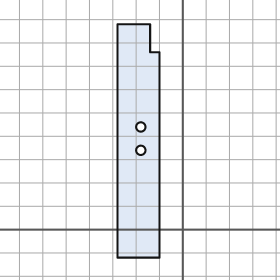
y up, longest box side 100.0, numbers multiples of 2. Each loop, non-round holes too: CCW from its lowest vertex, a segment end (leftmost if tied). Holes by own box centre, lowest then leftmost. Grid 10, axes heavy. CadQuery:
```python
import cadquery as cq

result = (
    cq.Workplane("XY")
    .moveTo(-28.0, -12.0)
    .lineTo(-10.0, -12.0)
    .lineTo(-10.0, 76.0)
    .lineTo(-14.0, 76.0)
    .lineTo(-14.0, 88.0)
    .lineTo(-28.0, 88.0)
    .close()
    .moveTo(-18.0, 34.0)
    .circle(2.0)
    .moveTo(-18.0, 44.0)
    .circle(2.0)
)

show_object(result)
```